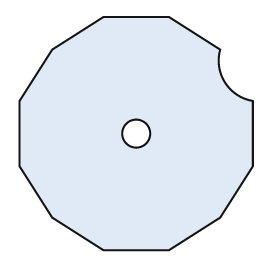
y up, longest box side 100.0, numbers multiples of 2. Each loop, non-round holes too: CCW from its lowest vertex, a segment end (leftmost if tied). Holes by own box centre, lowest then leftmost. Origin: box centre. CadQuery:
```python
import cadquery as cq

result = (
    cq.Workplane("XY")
    .moveTo(-14.0, -50.0)
    .lineTo(14.0, -50.0)
    .lineTo(36.0, -36.0)
    .lineTo(50.0, -14.0)
    .lineTo(50.0, 14.0)
    .threePointArc((38.0, 22.0), (36.0, 36.0))
    .lineTo(14.0, 50.0)
    .lineTo(-14.0, 50.0)
    .lineTo(-36.0, 36.0)
    .lineTo(-50.0, 14.0)
    .lineTo(-50.0, -14.0)
    .lineTo(-36.0, -36.0)
    .close()
    .moveTo(0.0, 0.0)
    .circle(6.0)
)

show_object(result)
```